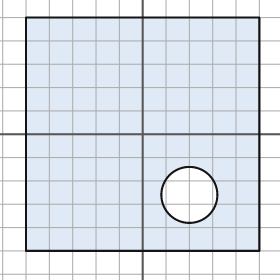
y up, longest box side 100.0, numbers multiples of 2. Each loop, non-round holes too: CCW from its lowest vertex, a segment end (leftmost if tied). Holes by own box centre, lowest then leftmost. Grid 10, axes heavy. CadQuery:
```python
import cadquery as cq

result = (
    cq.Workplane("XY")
    .moveTo(-50.0, -50.0)
    .lineTo(50.0, -50.0)
    .lineTo(50.0, 50.0)
    .lineTo(-50.0, 50.0)
    .close()
    .moveTo(20.0, -26.0)
    .circle(12.0)
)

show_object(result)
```